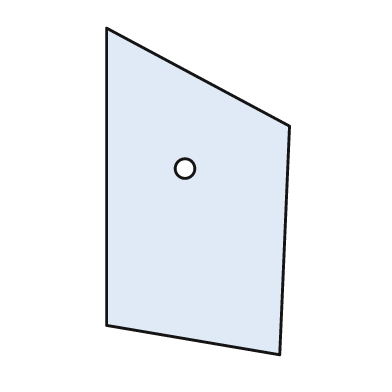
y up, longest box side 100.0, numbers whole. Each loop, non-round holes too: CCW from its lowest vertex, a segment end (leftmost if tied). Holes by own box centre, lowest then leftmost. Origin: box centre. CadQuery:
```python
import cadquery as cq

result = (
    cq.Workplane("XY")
    .moveTo(25.0, -50.0)
    .lineTo(28.0, 20.0)
    .lineTo(-28.0, 50.0)
    .lineTo(-28.0, -41.0)
    .close()
    .moveTo(-4.0, 7.0)
    .circle(3.0)
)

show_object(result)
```